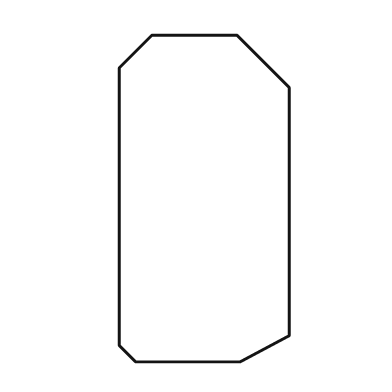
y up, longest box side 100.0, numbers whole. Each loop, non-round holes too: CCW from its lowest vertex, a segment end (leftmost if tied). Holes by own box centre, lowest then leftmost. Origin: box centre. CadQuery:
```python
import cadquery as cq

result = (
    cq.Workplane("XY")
    .moveTo(-21.0, -50.0)
    .lineTo(11.0, -50.0)
    .lineTo(26.0, -42.0)
    .lineTo(26.0, 34.0)
    .lineTo(10.0, 50.0)
    .lineTo(-16.0, 50.0)
    .lineTo(-26.0, 40.0)
    .lineTo(-26.0, -45.0)
    .close()
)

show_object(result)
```